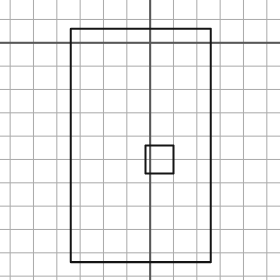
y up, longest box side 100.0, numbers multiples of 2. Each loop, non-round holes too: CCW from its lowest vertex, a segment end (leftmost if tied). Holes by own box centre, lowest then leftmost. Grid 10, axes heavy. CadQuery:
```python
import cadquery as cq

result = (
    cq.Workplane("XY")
    .moveTo(-34.0, -94.0)
    .lineTo(26.0, -94.0)
    .lineTo(26.0, 6.0)
    .lineTo(-34.0, 6.0)
    .close()
    .moveTo(-2.0, -56.0)
    .lineTo(10.0, -56.0)
    .lineTo(10.0, -44.0)
    .lineTo(-2.0, -44.0)
    .close()
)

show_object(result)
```